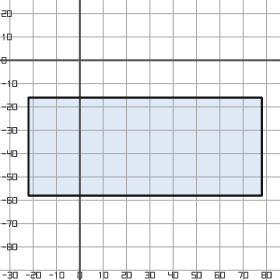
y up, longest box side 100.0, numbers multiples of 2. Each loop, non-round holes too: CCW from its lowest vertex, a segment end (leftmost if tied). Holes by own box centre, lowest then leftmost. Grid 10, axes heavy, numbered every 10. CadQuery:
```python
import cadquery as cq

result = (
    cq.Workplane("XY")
    .moveTo(-22.0, -58.0)
    .lineTo(78.0, -58.0)
    .lineTo(78.0, -16.0)
    .lineTo(-22.0, -16.0)
    .close()
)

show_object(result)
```